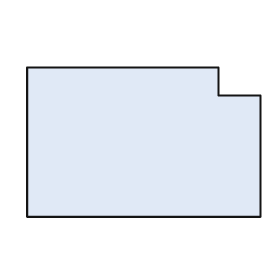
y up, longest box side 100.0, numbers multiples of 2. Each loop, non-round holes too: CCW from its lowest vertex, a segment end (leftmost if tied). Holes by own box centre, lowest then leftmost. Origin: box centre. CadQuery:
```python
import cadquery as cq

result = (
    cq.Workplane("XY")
    .moveTo(-50.0, -32.0)
    .lineTo(50.0, -32.0)
    .lineTo(50.0, 20.0)
    .lineTo(32.0, 20.0)
    .lineTo(32.0, 32.0)
    .lineTo(-50.0, 32.0)
    .close()
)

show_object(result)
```